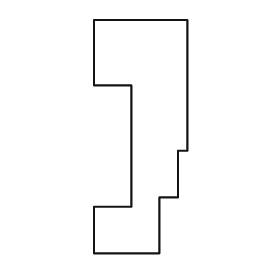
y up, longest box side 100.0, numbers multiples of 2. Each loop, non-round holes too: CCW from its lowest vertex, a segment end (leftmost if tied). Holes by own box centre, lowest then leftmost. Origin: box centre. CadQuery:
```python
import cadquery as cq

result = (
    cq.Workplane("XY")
    .moveTo(-20.0, -50.0)
    .lineTo(8.0, -50.0)
    .lineTo(8.0, -26.0)
    .lineTo(16.0, -26.0)
    .lineTo(16.0, -6.0)
    .lineTo(20.0, -6.0)
    .lineTo(20.0, 50.0)
    .lineTo(-20.0, 50.0)
    .lineTo(-20.0, 22.0)
    .lineTo(-4.0, 22.0)
    .lineTo(-4.0, -30.0)
    .lineTo(-20.0, -30.0)
    .close()
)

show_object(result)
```